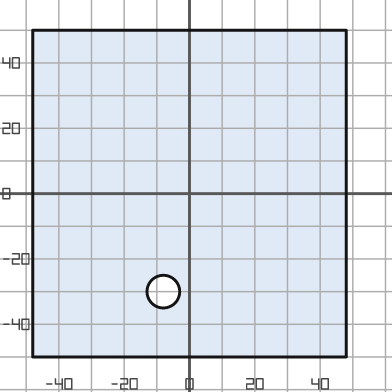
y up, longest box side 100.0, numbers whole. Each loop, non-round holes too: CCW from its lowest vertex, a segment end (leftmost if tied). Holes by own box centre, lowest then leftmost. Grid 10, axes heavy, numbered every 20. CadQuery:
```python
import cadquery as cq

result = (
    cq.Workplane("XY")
    .moveTo(-48.0, -50.0)
    .lineTo(48.0, -50.0)
    .lineTo(48.0, 50.0)
    .lineTo(-48.0, 50.0)
    .close()
    .moveTo(-8.0, -30.0)
    .circle(5.0)
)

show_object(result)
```